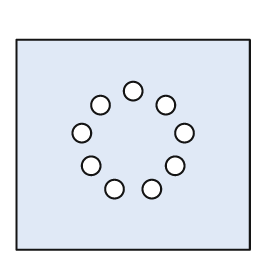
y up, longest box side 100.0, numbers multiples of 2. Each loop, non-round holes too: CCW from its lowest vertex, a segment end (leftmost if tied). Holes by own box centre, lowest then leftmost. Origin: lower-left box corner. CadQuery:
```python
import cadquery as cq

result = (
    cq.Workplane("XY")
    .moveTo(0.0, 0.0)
    .lineTo(100.0, 0.0)
    .lineTo(100.0, 90.0)
    .lineTo(0.0, 90.0)
    .close()
    .moveTo(42.0, 26.0)
    .circle(4.0)
    .moveTo(58.0, 26.0)
    .circle(4.0)
    .moveTo(32.0, 36.0)
    .circle(4.0)
    .moveTo(68.0, 36.0)
    .circle(4.0)
    .moveTo(28.0, 50.0)
    .circle(4.0)
    .moveTo(72.0, 50.0)
    .circle(4.0)
    .moveTo(36.0, 62.0)
    .circle(4.0)
    .moveTo(64.0, 62.0)
    .circle(4.0)
    .moveTo(50.0, 68.0)
    .circle(4.0)
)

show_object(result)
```